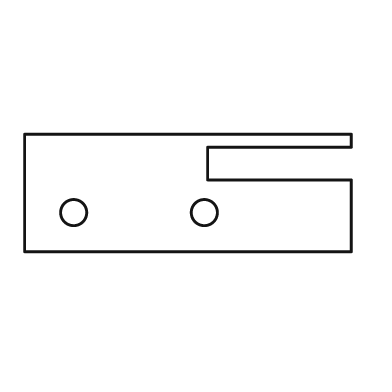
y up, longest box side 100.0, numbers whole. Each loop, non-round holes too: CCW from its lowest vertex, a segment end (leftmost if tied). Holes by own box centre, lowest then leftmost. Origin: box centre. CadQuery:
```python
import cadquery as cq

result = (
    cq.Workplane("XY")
    .moveTo(-50.0, -18.0)
    .lineTo(50.0, -18.0)
    .lineTo(50.0, 4.0)
    .lineTo(6.0, 4.0)
    .lineTo(6.0, 14.0)
    .lineTo(50.0, 14.0)
    .lineTo(50.0, 18.0)
    .lineTo(-50.0, 18.0)
    .close()
    .moveTo(-35.0, -6.0)
    .circle(4.0)
    .moveTo(5.0, -6.0)
    .circle(4.0)
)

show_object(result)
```